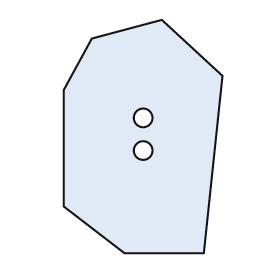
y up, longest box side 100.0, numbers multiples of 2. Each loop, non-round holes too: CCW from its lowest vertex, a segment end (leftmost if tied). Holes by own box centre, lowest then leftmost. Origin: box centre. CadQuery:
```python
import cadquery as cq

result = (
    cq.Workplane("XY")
    .moveTo(-8.0, -50.0)
    .lineTo(26.0, -50.0)
    .lineTo(34.0, 26.0)
    .lineTo(8.0, 50.0)
    .lineTo(-22.0, 42.0)
    .lineTo(-34.0, 20.0)
    .lineTo(-34.0, -30.0)
    .close()
    .moveTo(0.0, -6.0)
    .circle(4.0)
    .moveTo(0.0, 8.0)
    .circle(4.0)
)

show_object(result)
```